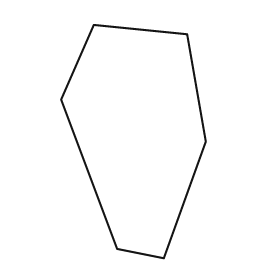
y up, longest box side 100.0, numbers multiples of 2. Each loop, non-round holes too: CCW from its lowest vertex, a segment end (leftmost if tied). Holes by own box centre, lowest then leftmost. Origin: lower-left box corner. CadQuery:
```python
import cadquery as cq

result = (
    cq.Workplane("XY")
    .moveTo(44.0, 0.0)
    .lineTo(62.0, 50.0)
    .lineTo(54.0, 96.0)
    .lineTo(14.0, 100.0)
    .lineTo(0.0, 68.0)
    .lineTo(24.0, 4.0)
    .close()
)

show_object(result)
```